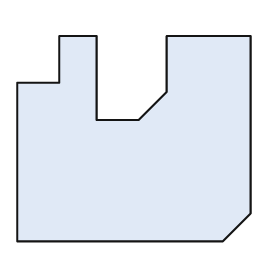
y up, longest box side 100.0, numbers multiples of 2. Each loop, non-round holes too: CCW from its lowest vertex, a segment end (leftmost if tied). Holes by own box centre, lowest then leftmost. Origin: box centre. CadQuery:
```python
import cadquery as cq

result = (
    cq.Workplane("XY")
    .moveTo(-50.0, -44.0)
    .lineTo(38.0, -44.0)
    .lineTo(50.0, -32.0)
    .lineTo(50.0, 44.0)
    .lineTo(14.0, 44.0)
    .lineTo(14.0, 20.0)
    .lineTo(2.0, 8.0)
    .lineTo(-16.0, 8.0)
    .lineTo(-16.0, 44.0)
    .lineTo(-32.0, 44.0)
    .lineTo(-32.0, 24.0)
    .lineTo(-50.0, 24.0)
    .close()
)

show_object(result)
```